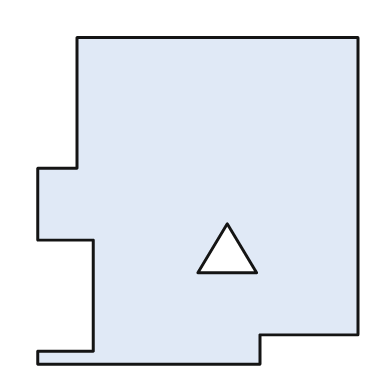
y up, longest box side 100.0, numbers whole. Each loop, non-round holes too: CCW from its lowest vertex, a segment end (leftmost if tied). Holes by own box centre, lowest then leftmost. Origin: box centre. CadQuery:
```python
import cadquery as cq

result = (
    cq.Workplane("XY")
    .moveTo(-49.0, -50.0)
    .lineTo(19.0, -50.0)
    .lineTo(19.0, -41.0)
    .lineTo(49.0, -41.0)
    .lineTo(49.0, 50.0)
    .lineTo(-37.0, 50.0)
    .lineTo(-37.0, 10.0)
    .lineTo(-49.0, 10.0)
    .lineTo(-49.0, -12.0)
    .lineTo(-32.0, -12.0)
    .lineTo(-32.0, -46.0)
    .lineTo(-49.0, -46.0)
    .close()
    .moveTo(0.0, -22.0)
    .lineTo(18.0, -22.0)
    .lineTo(9.0, -7.0)
    .close()
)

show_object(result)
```